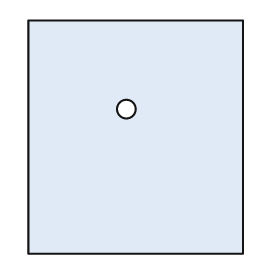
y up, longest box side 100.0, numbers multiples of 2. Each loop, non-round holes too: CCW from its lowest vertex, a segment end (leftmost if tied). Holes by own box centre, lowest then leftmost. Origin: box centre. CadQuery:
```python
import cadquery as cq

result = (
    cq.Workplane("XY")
    .moveTo(-46.0, -50.0)
    .lineTo(46.0, -50.0)
    .lineTo(46.0, 50.0)
    .lineTo(-46.0, 50.0)
    .close()
    .moveTo(-4.0, 12.0)
    .circle(4.0)
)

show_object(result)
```